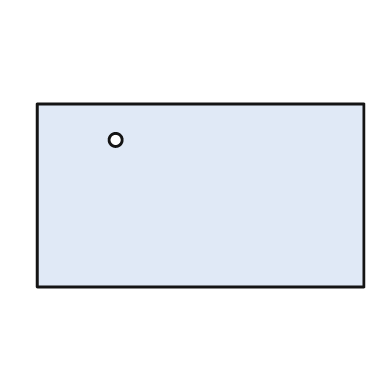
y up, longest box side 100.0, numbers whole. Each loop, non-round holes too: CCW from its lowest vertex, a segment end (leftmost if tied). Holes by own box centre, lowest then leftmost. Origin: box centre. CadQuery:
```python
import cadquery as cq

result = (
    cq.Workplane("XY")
    .moveTo(-50.0, -28.0)
    .lineTo(50.0, -28.0)
    .lineTo(50.0, 28.0)
    .lineTo(-50.0, 28.0)
    .close()
    .moveTo(-26.0, 17.0)
    .circle(2.0)
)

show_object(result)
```